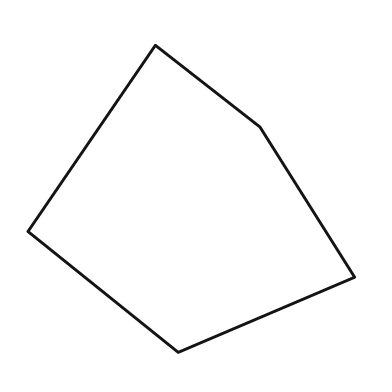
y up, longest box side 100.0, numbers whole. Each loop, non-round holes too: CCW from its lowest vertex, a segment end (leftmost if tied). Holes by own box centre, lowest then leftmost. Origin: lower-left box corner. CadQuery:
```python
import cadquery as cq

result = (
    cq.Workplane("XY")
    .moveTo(46.0, 0.0)
    .lineTo(100.0, 23.0)
    .lineTo(71.0, 69.0)
    .lineTo(39.0, 94.0)
    .lineTo(0.0, 37.0)
    .close()
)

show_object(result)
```